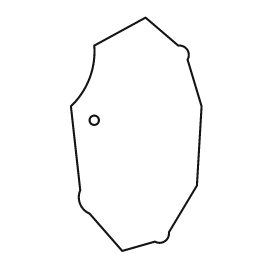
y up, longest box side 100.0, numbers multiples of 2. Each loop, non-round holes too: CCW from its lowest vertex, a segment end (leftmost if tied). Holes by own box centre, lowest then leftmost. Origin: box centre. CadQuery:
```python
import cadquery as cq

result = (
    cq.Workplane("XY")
    .moveTo(-6.0, -50.0)
    .lineTo(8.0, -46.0)
    .threePointArc((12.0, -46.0), (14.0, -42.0))
    .lineTo(26.0, -22.0)
    .lineTo(28.0, 12.0)
    .lineTo(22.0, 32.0)
    .threePointArc((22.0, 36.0), (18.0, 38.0))
    .lineTo(4.0, 50.0)
    .lineTo(-18.0, 38.0)
    .threePointArc((-20.0, 24.0), (-28.0, 12.0))
    .lineTo(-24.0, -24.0)
    .threePointArc((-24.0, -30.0), (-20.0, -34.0))
    .close()
    .moveTo(-18.0, 6.0)
    .circle(2.0)
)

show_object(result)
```